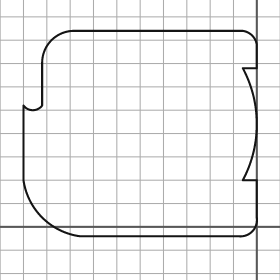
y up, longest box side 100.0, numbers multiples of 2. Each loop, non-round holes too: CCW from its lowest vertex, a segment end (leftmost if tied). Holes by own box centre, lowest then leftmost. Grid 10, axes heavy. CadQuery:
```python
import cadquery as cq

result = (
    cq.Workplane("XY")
    .moveTo(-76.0, -4.0)
    .lineTo(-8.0, -4.0)
    .threePointArc((-2.0, -2.0), (0.0, 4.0))
    .lineTo(0.0, 20.0)
    .lineTo(-6.0, 20.0)
    .threePointArc((0.0, 44.0), (-6.0, 68.0))
    .lineTo(0.0, 68.0)
    .lineTo(0.0, 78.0)
    .threePointArc((-2.0, 82.0), (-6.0, 84.0))
    .lineTo(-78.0, 84.0)
    .threePointArc((-88.0, 80.0), (-92.0, 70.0))
    .lineTo(-92.0, 52.0)
    .threePointArc((-96.0, 50.0), (-100.0, 52.0))
    .lineTo(-100.0, 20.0)
    .threePointArc((-92.0, 4.0), (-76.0, -4.0))
    .close()
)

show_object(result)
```